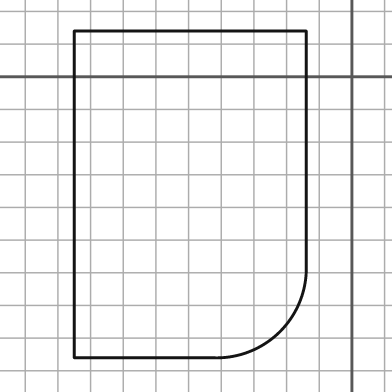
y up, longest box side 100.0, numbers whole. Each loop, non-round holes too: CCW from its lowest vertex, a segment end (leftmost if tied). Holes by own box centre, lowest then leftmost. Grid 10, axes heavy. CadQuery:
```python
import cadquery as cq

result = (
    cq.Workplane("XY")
    .moveTo(-85.0, -86.0)
    .lineTo(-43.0, -86.0)
    .threePointArc((-22.0, -78.0), (-14.0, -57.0))
    .lineTo(-14.0, 14.0)
    .lineTo(-85.0, 14.0)
    .close()
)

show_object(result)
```